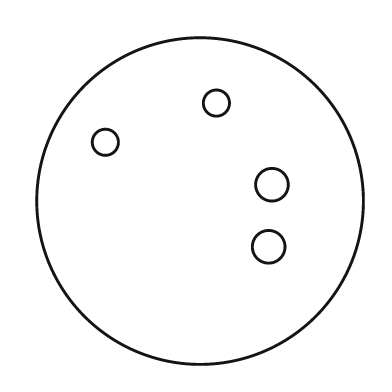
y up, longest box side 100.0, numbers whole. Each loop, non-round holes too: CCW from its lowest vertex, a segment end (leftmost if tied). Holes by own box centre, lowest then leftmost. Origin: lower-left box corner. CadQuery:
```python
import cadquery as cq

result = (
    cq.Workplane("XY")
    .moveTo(50.0, 50.0)
    .circle(50.0)
    .moveTo(71.0, 36.0)
    .circle(5.0)
    .moveTo(72.0, 55.0)
    .circle(5.0)
    .moveTo(21.0, 68.0)
    .circle(4.0)
    .moveTo(55.0, 80.0)
    .circle(4.0)
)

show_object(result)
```